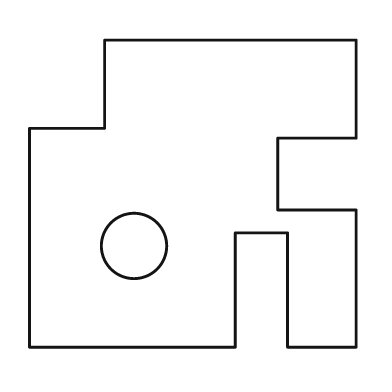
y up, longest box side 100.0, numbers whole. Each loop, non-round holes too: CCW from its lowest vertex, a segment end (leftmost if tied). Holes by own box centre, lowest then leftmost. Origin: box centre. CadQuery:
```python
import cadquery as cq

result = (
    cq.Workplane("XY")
    .moveTo(-50.0, -47.0)
    .lineTo(13.0, -47.0)
    .lineTo(13.0, -12.0)
    .lineTo(29.0, -12.0)
    .lineTo(29.0, -47.0)
    .lineTo(50.0, -47.0)
    .lineTo(50.0, -5.0)
    .lineTo(26.0, -5.0)
    .lineTo(26.0, 17.0)
    .lineTo(50.0, 17.0)
    .lineTo(50.0, 47.0)
    .lineTo(-27.0, 47.0)
    .lineTo(-27.0, 20.0)
    .lineTo(-50.0, 20.0)
    .close()
    .moveTo(-18.0, -16.0)
    .circle(10.0)
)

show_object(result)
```